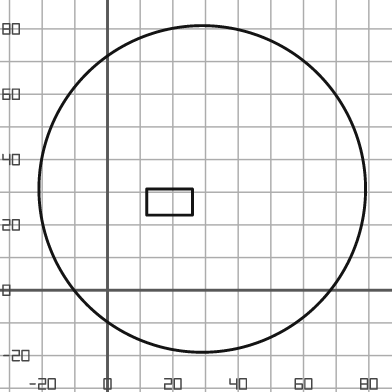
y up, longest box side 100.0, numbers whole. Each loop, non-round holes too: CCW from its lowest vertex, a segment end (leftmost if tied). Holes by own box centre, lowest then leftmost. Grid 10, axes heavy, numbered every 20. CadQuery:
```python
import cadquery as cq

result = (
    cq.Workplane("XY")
    .moveTo(29.0, 31.0)
    .circle(50.0)
    .moveTo(12.0, 23.0)
    .lineTo(26.0, 23.0)
    .lineTo(26.0, 31.0)
    .lineTo(12.0, 31.0)
    .close()
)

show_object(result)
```